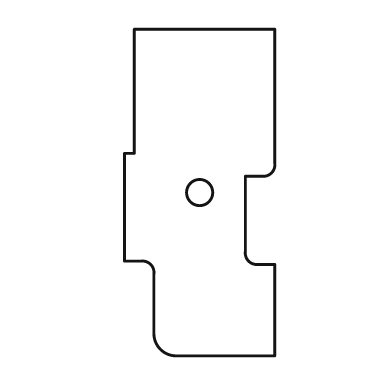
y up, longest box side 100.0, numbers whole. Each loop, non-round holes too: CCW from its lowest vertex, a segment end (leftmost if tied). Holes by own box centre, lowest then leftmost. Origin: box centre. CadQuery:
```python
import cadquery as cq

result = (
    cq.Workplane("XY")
    .moveTo(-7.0, -50.0)
    .lineTo(23.0, -50.0)
    .lineTo(23.0, -22.0)
    .lineTo(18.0, -22.0)
    .threePointArc((15.0, -21.0), (14.0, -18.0))
    .lineTo(14.0, 5.0)
    .lineTo(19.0, 5.0)
    .threePointArc((22.0, 6.0), (23.0, 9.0))
    .lineTo(23.0, 50.0)
    .lineTo(-20.0, 50.0)
    .lineTo(-20.0, 12.0)
    .lineTo(-23.0, 12.0)
    .lineTo(-23.0, -21.0)
    .lineTo(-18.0, -21.0)
    .threePointArc((-15.0, -22.0), (-14.0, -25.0))
    .lineTo(-14.0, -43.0)
    .threePointArc((-12.0, -48.0), (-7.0, -50.0))
    .close()
    .moveTo(0.0, 0.0)
    .circle(4.0)
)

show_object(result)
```